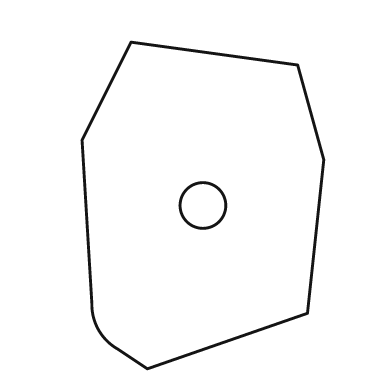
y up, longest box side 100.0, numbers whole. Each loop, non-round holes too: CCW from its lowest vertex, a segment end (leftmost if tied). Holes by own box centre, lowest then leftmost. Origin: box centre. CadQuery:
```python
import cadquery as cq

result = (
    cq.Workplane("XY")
    .moveTo(-17.0, -50.0)
    .lineTo(32.0, -33.0)
    .lineTo(37.0, 14.0)
    .lineTo(29.0, 43.0)
    .lineTo(-22.0, 50.0)
    .lineTo(-37.0, 20.0)
    .lineTo(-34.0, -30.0)
    .threePointArc((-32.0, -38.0), (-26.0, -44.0))
    .close()
    .moveTo(0.0, 0.0)
    .circle(7.0)
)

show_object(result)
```